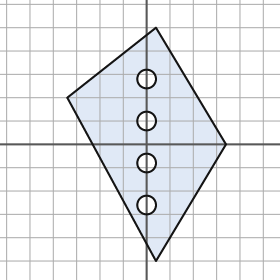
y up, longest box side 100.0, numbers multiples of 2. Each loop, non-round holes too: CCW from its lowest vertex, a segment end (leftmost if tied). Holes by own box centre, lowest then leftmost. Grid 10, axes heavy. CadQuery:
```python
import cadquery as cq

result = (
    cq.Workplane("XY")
    .moveTo(4.0, -50.0)
    .lineTo(34.0, 0.0)
    .lineTo(4.0, 50.0)
    .lineTo(-34.0, 20.0)
    .close()
    .moveTo(0.0, -26.0)
    .circle(4.0)
    .moveTo(0.0, -8.0)
    .circle(4.0)
    .moveTo(0.0, 10.0)
    .circle(4.0)
    .moveTo(0.0, 28.0)
    .circle(4.0)
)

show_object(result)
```